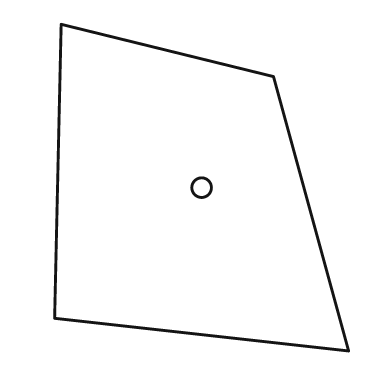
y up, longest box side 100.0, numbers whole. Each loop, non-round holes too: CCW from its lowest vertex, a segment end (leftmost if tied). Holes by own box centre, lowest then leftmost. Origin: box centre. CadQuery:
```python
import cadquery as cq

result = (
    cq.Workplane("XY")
    .moveTo(45.0, -50.0)
    .lineTo(22.0, 34.0)
    .lineTo(-43.0, 50.0)
    .lineTo(-45.0, -40.0)
    .close()
    .moveTo(0.0, 0.0)
    .circle(3.0)
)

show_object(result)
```